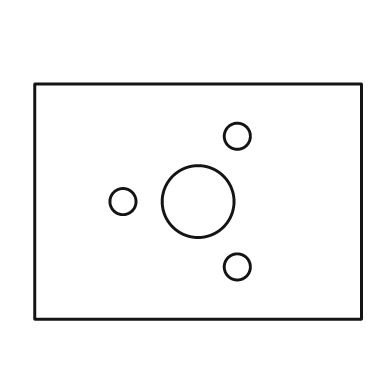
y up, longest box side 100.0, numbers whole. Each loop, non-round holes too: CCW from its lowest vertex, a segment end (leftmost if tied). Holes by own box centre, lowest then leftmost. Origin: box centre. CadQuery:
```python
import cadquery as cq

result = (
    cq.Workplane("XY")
    .moveTo(-50.0, -36.0)
    .lineTo(50.0, -36.0)
    .lineTo(50.0, 36.0)
    .lineTo(-50.0, 36.0)
    .close()
    .moveTo(12.0, -20.0)
    .circle(4.0)
    .moveTo(-23.0, 0.0)
    .circle(4.0)
    .moveTo(0.0, 0.0)
    .circle(11.0)
    .moveTo(12.0, 20.0)
    .circle(4.0)
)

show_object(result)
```